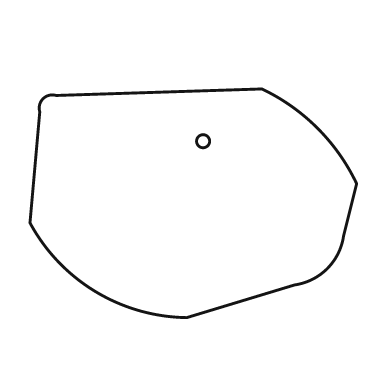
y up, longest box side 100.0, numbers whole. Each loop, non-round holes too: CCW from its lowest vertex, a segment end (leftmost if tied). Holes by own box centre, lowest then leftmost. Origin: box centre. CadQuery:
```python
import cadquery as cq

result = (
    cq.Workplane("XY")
    .moveTo(-2.0, -35.0)
    .lineTo(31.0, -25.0)
    .threePointArc((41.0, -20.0), (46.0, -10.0))
    .lineTo(50.0, 6.0)
    .threePointArc((38.0, 23.0), (21.0, 35.0))
    .lineTo(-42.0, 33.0)
    .threePointArc((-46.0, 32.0), (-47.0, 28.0))
    .lineTo(-50.0, -6.0)
    .threePointArc((-30.0, -27.0), (-2.0, -35.0))
    .close()
    .moveTo(3.0, 19.0)
    .circle(2.0)
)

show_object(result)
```